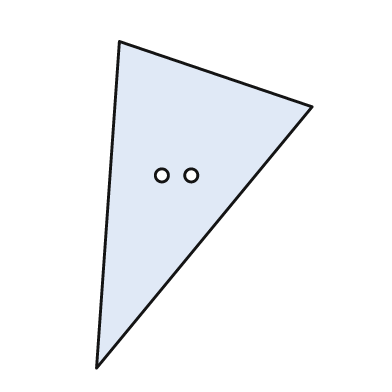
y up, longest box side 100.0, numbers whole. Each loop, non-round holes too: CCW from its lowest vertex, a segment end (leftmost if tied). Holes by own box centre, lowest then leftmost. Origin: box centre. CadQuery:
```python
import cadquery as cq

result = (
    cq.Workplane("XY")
    .moveTo(-33.0, -50.0)
    .lineTo(33.0, 30.0)
    .lineTo(-26.0, 50.0)
    .close()
    .moveTo(-13.0, 9.0)
    .circle(2.0)
    .moveTo(-4.0, 9.0)
    .circle(2.0)
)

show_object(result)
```